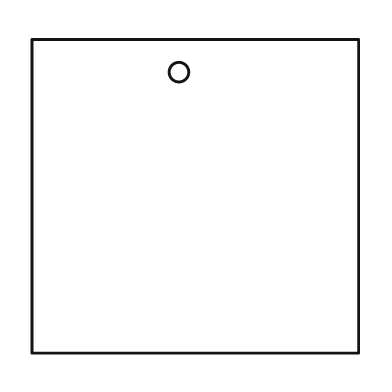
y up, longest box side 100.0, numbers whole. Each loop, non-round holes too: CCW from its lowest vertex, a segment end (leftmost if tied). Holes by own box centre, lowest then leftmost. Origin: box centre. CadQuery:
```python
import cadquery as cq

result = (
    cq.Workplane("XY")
    .moveTo(-50.0, -48.0)
    .lineTo(50.0, -48.0)
    .lineTo(50.0, 48.0)
    .lineTo(-50.0, 48.0)
    .close()
    .moveTo(-5.0, 38.0)
    .circle(3.0)
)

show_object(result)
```